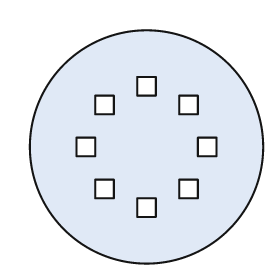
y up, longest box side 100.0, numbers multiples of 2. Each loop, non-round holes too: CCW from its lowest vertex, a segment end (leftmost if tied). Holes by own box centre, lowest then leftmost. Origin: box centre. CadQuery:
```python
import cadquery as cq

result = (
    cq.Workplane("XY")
    .moveTo(0.0, 0.0)
    .circle(50.0)
    .moveTo(-4.0, -30.0)
    .lineTo(4.0, -30.0)
    .lineTo(4.0, -22.0)
    .lineTo(-4.0, -22.0)
    .close()
    .moveTo(-22.0, -22.0)
    .lineTo(-14.0, -22.0)
    .lineTo(-14.0, -14.0)
    .lineTo(-22.0, -14.0)
    .close()
    .moveTo(14.0, -22.0)
    .lineTo(22.0, -22.0)
    .lineTo(22.0, -14.0)
    .lineTo(14.0, -14.0)
    .close()
    .moveTo(-30.0, -4.0)
    .lineTo(-22.0, -4.0)
    .lineTo(-22.0, 4.0)
    .lineTo(-30.0, 4.0)
    .close()
    .moveTo(22.0, -4.0)
    .lineTo(30.0, -4.0)
    .lineTo(30.0, 4.0)
    .lineTo(22.0, 4.0)
    .close()
    .moveTo(-22.0, 14.0)
    .lineTo(-14.0, 14.0)
    .lineTo(-14.0, 22.0)
    .lineTo(-22.0, 22.0)
    .close()
    .moveTo(14.0, 14.0)
    .lineTo(22.0, 14.0)
    .lineTo(22.0, 22.0)
    .lineTo(14.0, 22.0)
    .close()
    .moveTo(-4.0, 22.0)
    .lineTo(4.0, 22.0)
    .lineTo(4.0, 30.0)
    .lineTo(-4.0, 30.0)
    .close()
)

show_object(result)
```